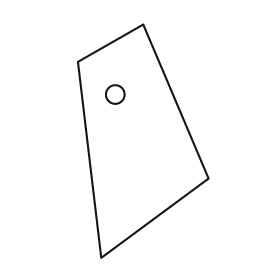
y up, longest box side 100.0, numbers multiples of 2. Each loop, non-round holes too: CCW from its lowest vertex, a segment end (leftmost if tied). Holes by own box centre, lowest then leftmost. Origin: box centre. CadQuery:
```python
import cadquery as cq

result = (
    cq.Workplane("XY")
    .moveTo(-18.0, -50.0)
    .lineTo(28.0, -16.0)
    .lineTo(0.0, 50.0)
    .lineTo(-28.0, 34.0)
    .close()
    .moveTo(-12.0, 20.0)
    .circle(4.0)
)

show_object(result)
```